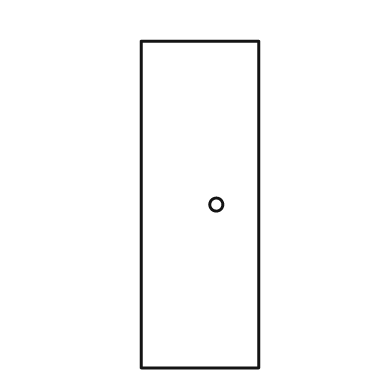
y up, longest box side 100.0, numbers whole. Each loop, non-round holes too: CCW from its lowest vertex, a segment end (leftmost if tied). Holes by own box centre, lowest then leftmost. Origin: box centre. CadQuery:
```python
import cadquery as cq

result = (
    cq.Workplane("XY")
    .moveTo(-18.0, -50.0)
    .lineTo(18.0, -50.0)
    .lineTo(18.0, 50.0)
    .lineTo(-18.0, 50.0)
    .close()
    .moveTo(5.0, 0.0)
    .circle(2.0)
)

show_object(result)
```